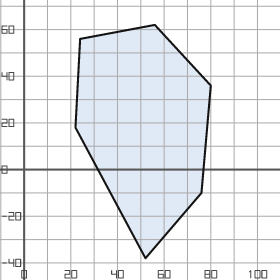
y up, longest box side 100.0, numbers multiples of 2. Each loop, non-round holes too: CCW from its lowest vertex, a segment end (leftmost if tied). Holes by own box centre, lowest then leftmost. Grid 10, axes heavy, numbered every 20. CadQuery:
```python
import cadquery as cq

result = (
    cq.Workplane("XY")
    .moveTo(52.0, -38.0)
    .lineTo(76.0, -10.0)
    .lineTo(80.0, 36.0)
    .lineTo(56.0, 62.0)
    .lineTo(24.0, 56.0)
    .lineTo(22.0, 18.0)
    .close()
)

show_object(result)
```